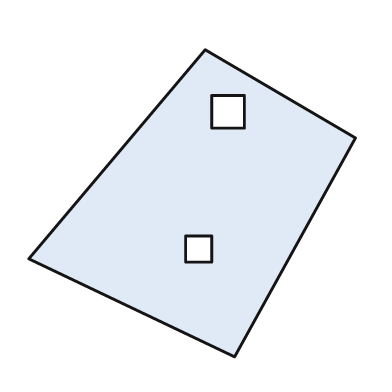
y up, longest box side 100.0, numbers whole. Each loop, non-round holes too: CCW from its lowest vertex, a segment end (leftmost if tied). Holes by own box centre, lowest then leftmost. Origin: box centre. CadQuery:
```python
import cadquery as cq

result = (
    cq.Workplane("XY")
    .moveTo(13.0, -47.0)
    .lineTo(50.0, 20.0)
    .lineTo(4.0, 47.0)
    .lineTo(-50.0, -17.0)
    .close()
    .moveTo(-2.0, -18.0)
    .lineTo(6.0, -18.0)
    .lineTo(6.0, -10.0)
    .lineTo(-2.0, -10.0)
    .close()
    .moveTo(6.0, 23.0)
    .lineTo(16.0, 23.0)
    .lineTo(16.0, 33.0)
    .lineTo(6.0, 33.0)
    .close()
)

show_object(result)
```